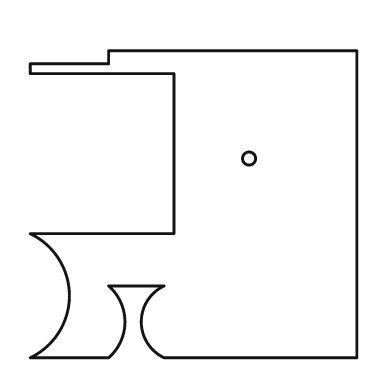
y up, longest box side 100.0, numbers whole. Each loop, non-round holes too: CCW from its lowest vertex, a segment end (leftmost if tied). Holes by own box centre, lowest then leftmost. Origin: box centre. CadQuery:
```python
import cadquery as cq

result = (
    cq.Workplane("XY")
    .moveTo(-50.0, -47.0)
    .lineTo(-26.0, -47.0)
    .threePointArc((-21.0, -36.0), (-26.0, -25.0))
    .lineTo(-9.0, -25.0)
    .threePointArc((-16.0, -36.0), (-9.0, -47.0))
    .lineTo(50.0, -47.0)
    .lineTo(50.0, 47.0)
    .lineTo(-26.0, 47.0)
    .lineTo(-26.0, 43.0)
    .lineTo(-50.0, 43.0)
    .lineTo(-50.0, 40.0)
    .lineTo(-6.0, 40.0)
    .lineTo(-6.0, -9.0)
    .lineTo(-50.0, -9.0)
    .threePointArc((-38.0, -28.0), (-50.0, -47.0))
    .close()
    .moveTo(17.0, 14.0)
    .circle(2.0)
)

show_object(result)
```